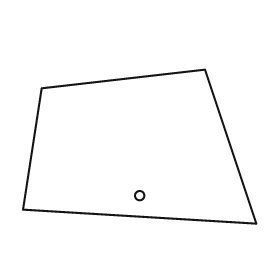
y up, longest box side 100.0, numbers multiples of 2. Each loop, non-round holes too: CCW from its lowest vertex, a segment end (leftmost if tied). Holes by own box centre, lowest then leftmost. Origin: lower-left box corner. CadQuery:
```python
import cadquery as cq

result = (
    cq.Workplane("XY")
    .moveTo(100.0, 0.0)
    .lineTo(78.0, 66.0)
    .lineTo(8.0, 58.0)
    .lineTo(0.0, 6.0)
    .close()
    .moveTo(50.0, 12.0)
    .circle(2.0)
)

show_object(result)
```